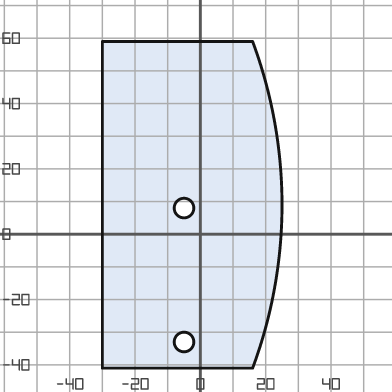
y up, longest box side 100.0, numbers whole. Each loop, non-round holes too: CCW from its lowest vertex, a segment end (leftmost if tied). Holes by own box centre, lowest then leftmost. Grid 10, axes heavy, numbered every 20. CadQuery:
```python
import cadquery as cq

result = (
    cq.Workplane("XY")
    .moveTo(-30.0, -41.0)
    .lineTo(16.0, -41.0)
    .threePointArc((25.0, 9.0), (16.0, 59.0))
    .lineTo(-30.0, 59.0)
    .close()
    .moveTo(-5.0, -33.0)
    .circle(3.0)
    .moveTo(-5.0, 8.0)
    .circle(3.0)
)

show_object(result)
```